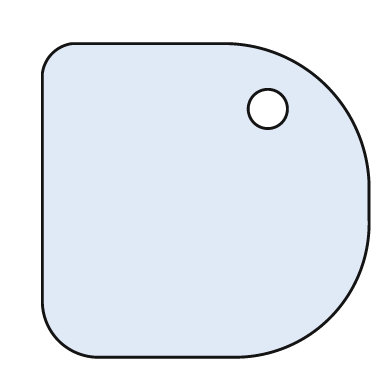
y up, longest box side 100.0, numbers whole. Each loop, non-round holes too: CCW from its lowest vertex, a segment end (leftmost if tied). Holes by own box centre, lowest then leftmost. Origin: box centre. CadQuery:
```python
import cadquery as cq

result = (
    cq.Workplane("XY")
    .moveTo(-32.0, -48.0)
    .lineTo(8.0, -48.0)
    .threePointArc((38.0, -36.0), (50.0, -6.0))
    .lineTo(50.0, 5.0)
    .threePointArc((37.0, 35.0), (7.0, 48.0))
    .lineTo(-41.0, 48.0)
    .threePointArc((-47.0, 45.0), (-50.0, 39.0))
    .lineTo(-50.0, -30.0)
    .threePointArc((-45.0, -43.0), (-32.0, -48.0))
    .close()
    .moveTo(19.0, 28.0)
    .circle(6.0)
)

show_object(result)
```